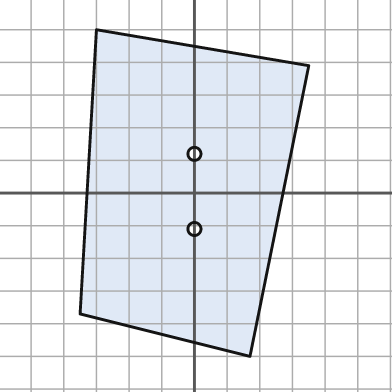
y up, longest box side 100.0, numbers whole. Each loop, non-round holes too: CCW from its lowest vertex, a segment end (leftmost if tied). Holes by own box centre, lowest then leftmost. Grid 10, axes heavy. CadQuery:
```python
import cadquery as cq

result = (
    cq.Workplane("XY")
    .moveTo(17.0, -50.0)
    .lineTo(35.0, 39.0)
    .lineTo(-30.0, 50.0)
    .lineTo(-35.0, -37.0)
    .close()
    .moveTo(0.0, -11.0)
    .circle(2.0)
    .moveTo(0.0, 12.0)
    .circle(2.0)
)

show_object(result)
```